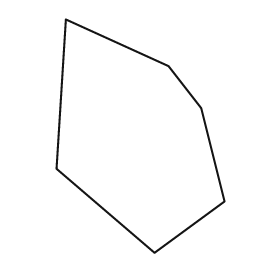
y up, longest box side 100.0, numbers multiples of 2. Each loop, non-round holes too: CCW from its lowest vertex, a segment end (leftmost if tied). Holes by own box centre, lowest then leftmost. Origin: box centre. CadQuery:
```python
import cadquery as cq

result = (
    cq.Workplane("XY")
    .moveTo(6.0, -50.0)
    .lineTo(36.0, -28.0)
    .lineTo(26.0, 12.0)
    .lineTo(12.0, 30.0)
    .lineTo(-32.0, 50.0)
    .lineTo(-36.0, -14.0)
    .close()
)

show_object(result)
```